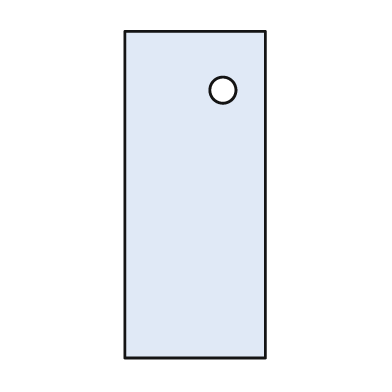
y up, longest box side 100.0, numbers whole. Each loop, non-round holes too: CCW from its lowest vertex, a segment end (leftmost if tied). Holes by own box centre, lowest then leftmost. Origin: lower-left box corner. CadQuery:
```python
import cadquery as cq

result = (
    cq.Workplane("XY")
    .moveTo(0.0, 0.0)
    .lineTo(43.0, 0.0)
    .lineTo(43.0, 100.0)
    .lineTo(0.0, 100.0)
    .close()
    .moveTo(30.0, 82.0)
    .circle(4.0)
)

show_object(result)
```